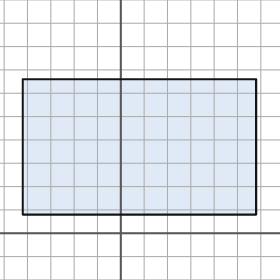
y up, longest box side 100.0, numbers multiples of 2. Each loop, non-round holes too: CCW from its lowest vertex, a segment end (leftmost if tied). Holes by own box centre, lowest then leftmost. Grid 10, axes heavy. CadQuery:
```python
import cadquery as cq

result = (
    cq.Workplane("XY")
    .moveTo(-42.0, 8.0)
    .lineTo(58.0, 8.0)
    .lineTo(58.0, 66.0)
    .lineTo(-42.0, 66.0)
    .close()
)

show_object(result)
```